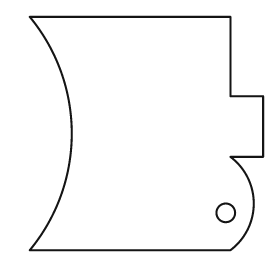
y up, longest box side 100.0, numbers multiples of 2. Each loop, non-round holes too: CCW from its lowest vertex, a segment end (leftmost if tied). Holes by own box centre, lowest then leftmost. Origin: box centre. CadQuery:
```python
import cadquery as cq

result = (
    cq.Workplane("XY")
    .moveTo(-50.0, -50.0)
    .lineTo(36.0, -50.0)
    .threePointArc((46.0, -30.0), (36.0, -10.0))
    .lineTo(50.0, -10.0)
    .lineTo(50.0, 16.0)
    .lineTo(36.0, 16.0)
    .lineTo(36.0, 50.0)
    .lineTo(-50.0, 50.0)
    .threePointArc((-32.0, 0.0), (-50.0, -50.0))
    .close()
    .moveTo(34.0, -34.0)
    .circle(4.0)
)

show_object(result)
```